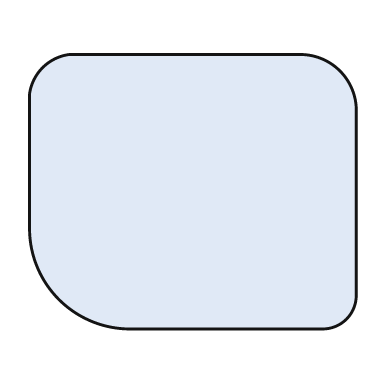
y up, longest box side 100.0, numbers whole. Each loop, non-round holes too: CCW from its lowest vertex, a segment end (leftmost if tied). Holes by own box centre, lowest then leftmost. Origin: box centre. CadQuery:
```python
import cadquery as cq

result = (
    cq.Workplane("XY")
    .moveTo(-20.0, -42.0)
    .lineTo(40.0, -42.0)
    .threePointArc((47.0, -39.0), (50.0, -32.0))
    .lineTo(50.0, 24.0)
    .threePointArc((45.0, 37.0), (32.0, 42.0))
    .lineTo(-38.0, 42.0)
    .threePointArc((-46.0, 38.0), (-50.0, 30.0))
    .lineTo(-50.0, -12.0)
    .threePointArc((-41.0, -33.0), (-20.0, -42.0))
    .close()
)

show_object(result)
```